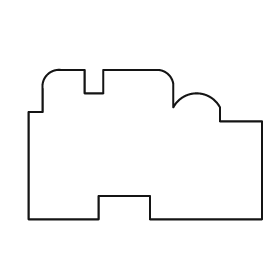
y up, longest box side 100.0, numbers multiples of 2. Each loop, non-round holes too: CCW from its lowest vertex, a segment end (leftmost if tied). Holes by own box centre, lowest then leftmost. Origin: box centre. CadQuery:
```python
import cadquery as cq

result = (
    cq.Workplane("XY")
    .moveTo(-50.0, -32.0)
    .lineTo(-20.0, -32.0)
    .lineTo(-20.0, -22.0)
    .lineTo(2.0, -22.0)
    .lineTo(2.0, -32.0)
    .lineTo(50.0, -32.0)
    .lineTo(50.0, 10.0)
    .lineTo(32.0, 10.0)
    .lineTo(32.0, 16.0)
    .threePointArc((22.0, 22.0), (12.0, 16.0))
    .lineTo(12.0, 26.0)
    .threePointArc((10.0, 30.0), (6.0, 32.0))
    .lineTo(-18.0, 32.0)
    .lineTo(-18.0, 22.0)
    .lineTo(-26.0, 22.0)
    .lineTo(-26.0, 32.0)
    .lineTo(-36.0, 32.0)
    .threePointArc((-42.0, 30.0), (-44.0, 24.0))
    .lineTo(-44.0, 14.0)
    .lineTo(-50.0, 14.0)
    .close()
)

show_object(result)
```